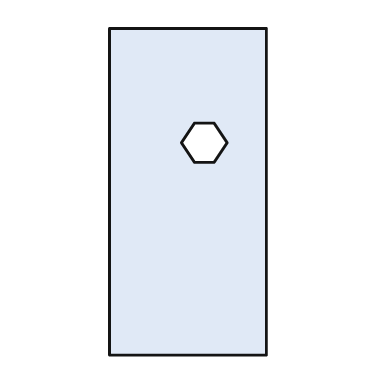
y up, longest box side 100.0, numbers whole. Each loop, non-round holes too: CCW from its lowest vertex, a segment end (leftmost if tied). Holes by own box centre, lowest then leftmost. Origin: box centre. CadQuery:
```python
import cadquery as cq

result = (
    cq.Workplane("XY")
    .moveTo(-24.0, -50.0)
    .lineTo(24.0, -50.0)
    .lineTo(24.0, 50.0)
    .lineTo(-24.0, 50.0)
    .close()
    .moveTo(2.0, 9.0)
    .lineTo(8.0, 9.0)
    .lineTo(12.0, 15.0)
    .lineTo(8.0, 21.0)
    .lineTo(2.0, 21.0)
    .lineTo(-2.0, 15.0)
    .close()
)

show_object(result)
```